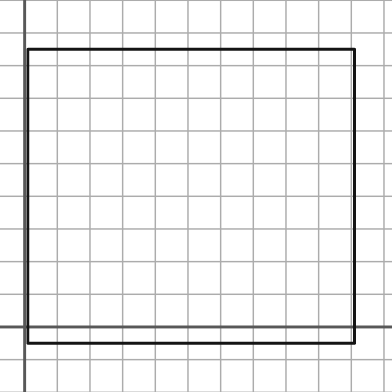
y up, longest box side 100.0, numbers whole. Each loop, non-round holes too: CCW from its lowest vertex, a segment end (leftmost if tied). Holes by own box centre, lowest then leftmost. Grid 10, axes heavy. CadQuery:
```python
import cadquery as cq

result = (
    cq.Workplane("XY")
    .moveTo(1.0, -5.0)
    .lineTo(101.0, -5.0)
    .lineTo(101.0, 85.0)
    .lineTo(1.0, 85.0)
    .close()
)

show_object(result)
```